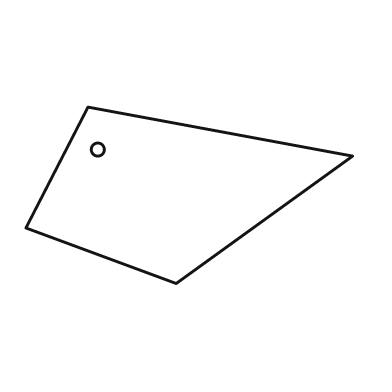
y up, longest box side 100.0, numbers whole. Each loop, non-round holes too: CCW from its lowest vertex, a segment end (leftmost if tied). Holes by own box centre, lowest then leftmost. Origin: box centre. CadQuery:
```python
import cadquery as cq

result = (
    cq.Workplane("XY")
    .moveTo(-4.0, -27.0)
    .lineTo(50.0, 12.0)
    .lineTo(-31.0, 27.0)
    .lineTo(-50.0, -10.0)
    .close()
    .moveTo(-28.0, 14.0)
    .circle(2.0)
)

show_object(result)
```